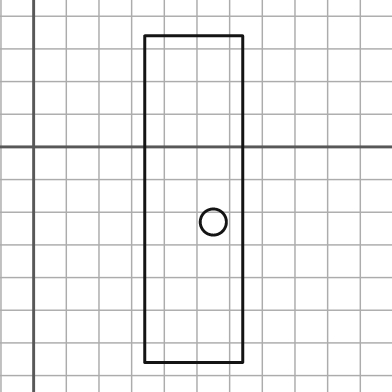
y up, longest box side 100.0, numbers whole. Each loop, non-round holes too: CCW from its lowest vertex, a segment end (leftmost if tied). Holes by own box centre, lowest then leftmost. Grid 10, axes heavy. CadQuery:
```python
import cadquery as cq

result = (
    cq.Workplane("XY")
    .moveTo(34.0, -66.0)
    .lineTo(64.0, -66.0)
    .lineTo(64.0, 34.0)
    .lineTo(34.0, 34.0)
    .close()
    .moveTo(55.0, -23.0)
    .circle(4.0)
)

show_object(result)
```